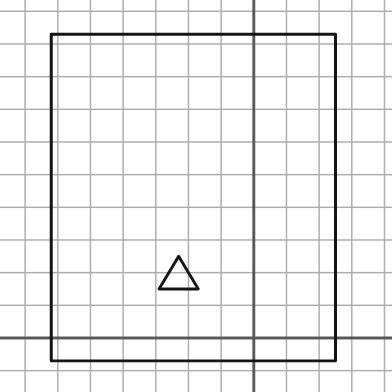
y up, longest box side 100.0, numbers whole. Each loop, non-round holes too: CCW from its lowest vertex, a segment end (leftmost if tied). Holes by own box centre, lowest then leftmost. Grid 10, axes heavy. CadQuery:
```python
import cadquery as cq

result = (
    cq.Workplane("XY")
    .moveTo(-62.0, -7.0)
    .lineTo(25.0, -7.0)
    .lineTo(25.0, 93.0)
    .lineTo(-62.0, 93.0)
    .close()
    .moveTo(-29.0, 15.0)
    .lineTo(-17.0, 15.0)
    .lineTo(-23.0, 25.0)
    .close()
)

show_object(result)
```